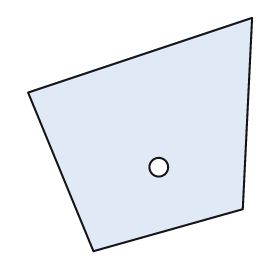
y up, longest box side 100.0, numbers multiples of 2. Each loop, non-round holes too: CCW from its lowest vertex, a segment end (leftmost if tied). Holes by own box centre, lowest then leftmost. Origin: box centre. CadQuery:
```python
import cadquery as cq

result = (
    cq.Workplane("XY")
    .moveTo(-20.0, -50.0)
    .lineTo(44.0, -32.0)
    .lineTo(48.0, 50.0)
    .lineTo(-48.0, 18.0)
    .close()
    .moveTo(8.0, -14.0)
    .circle(4.0)
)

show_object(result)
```